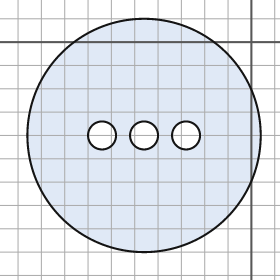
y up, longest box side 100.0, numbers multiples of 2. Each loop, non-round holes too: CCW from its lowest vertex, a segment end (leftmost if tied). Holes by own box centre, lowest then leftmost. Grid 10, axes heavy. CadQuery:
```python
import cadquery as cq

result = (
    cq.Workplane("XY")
    .moveTo(-46.0, -40.0)
    .circle(50.0)
    .moveTo(-64.0, -40.0)
    .circle(6.0)
    .moveTo(-46.0, -40.0)
    .circle(6.0)
    .moveTo(-28.0, -40.0)
    .circle(6.0)
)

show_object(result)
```